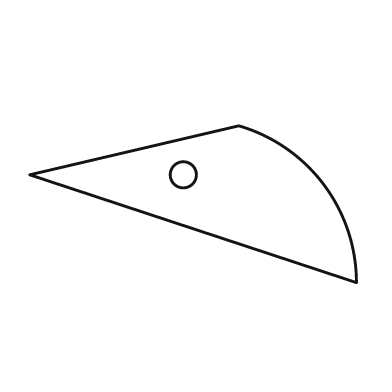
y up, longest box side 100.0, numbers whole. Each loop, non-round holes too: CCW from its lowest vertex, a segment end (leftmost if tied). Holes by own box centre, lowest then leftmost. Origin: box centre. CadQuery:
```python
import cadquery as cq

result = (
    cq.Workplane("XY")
    .moveTo(50.0, -24.0)
    .threePointArc((40.0, 6.0), (14.0, 24.0))
    .lineTo(-50.0, 9.0)
    .close()
    .moveTo(-3.0, 9.0)
    .circle(4.0)
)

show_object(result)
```